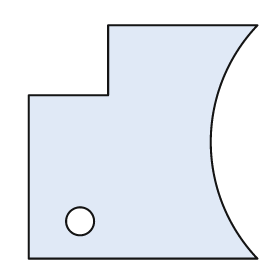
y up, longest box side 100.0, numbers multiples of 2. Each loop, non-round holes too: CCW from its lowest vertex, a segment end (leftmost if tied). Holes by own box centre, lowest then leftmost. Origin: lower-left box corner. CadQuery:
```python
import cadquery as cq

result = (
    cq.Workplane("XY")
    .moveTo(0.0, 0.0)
    .lineTo(98.0, 0.0)
    .threePointArc((78.0, 50.0), (98.0, 100.0))
    .lineTo(34.0, 100.0)
    .lineTo(34.0, 70.0)
    .lineTo(0.0, 70.0)
    .close()
    .moveTo(22.0, 16.0)
    .circle(6.0)
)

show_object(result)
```